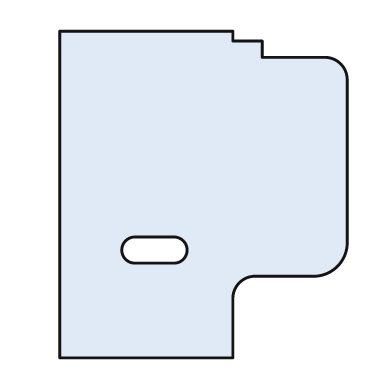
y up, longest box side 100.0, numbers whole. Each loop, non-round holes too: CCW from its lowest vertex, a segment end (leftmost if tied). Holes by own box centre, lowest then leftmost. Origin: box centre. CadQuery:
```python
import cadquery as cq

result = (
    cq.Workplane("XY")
    .moveTo(-44.0, -50.0)
    .lineTo(9.0, -50.0)
    .lineTo(9.0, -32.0)
    .threePointArc((11.0, -27.0), (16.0, -25.0))
    .lineTo(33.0, -25.0)
    .threePointArc((41.0, -22.0), (44.0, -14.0))
    .lineTo(44.0, 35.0)
    .threePointArc((42.0, 40.0), (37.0, 42.0))
    .lineTo(18.0, 42.0)
    .lineTo(18.0, 47.0)
    .lineTo(9.0, 47.0)
    .lineTo(9.0, 50.0)
    .lineTo(-44.0, 50.0)
    .close()
    .moveTo(-21.0, -21.0)
    .lineTo(-9.0, -21.0)
    .threePointArc((-5.0, -17.0), (-9.0, -13.0))
    .lineTo(-21.0, -13.0)
    .threePointArc((-25.0, -17.0), (-21.0, -21.0))
    .close()
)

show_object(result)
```